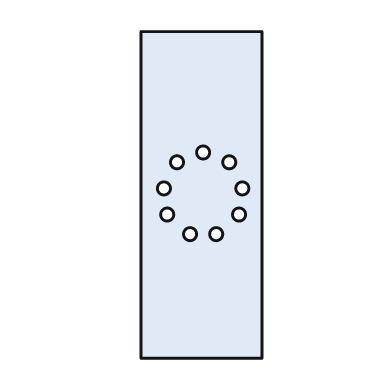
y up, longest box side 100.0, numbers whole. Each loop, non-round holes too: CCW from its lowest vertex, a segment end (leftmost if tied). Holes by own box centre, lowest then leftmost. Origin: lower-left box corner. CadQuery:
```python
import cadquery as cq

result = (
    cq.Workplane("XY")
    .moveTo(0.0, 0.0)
    .lineTo(37.0, 0.0)
    .lineTo(37.0, 100.0)
    .lineTo(0.0, 100.0)
    .close()
    .moveTo(15.0, 38.0)
    .circle(2.0)
    .moveTo(23.0, 38.0)
    .circle(2.0)
    .moveTo(8.0, 44.0)
    .circle(2.0)
    .moveTo(30.0, 44.0)
    .circle(2.0)
    .moveTo(7.0, 52.0)
    .circle(2.0)
    .moveTo(31.0, 52.0)
    .circle(2.0)
    .moveTo(11.0, 60.0)
    .circle(2.0)
    .moveTo(27.0, 60.0)
    .circle(2.0)
    .moveTo(19.0, 63.0)
    .circle(2.0)
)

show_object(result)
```